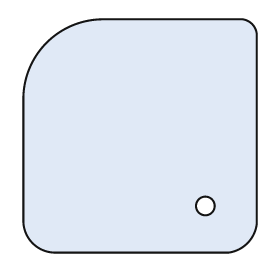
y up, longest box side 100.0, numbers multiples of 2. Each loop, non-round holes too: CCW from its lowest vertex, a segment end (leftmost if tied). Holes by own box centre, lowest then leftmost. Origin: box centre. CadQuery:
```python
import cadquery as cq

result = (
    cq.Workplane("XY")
    .moveTo(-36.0, -50.0)
    .lineTo(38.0, -50.0)
    .threePointArc((46.0, -46.0), (50.0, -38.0))
    .lineTo(50.0, 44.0)
    .threePointArc((48.0, 48.0), (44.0, 50.0))
    .lineTo(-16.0, 50.0)
    .threePointArc((-40.0, 40.0), (-50.0, 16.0))
    .lineTo(-50.0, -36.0)
    .threePointArc((-46.0, -46.0), (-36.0, -50.0))
    .close()
    .moveTo(28.0, -30.0)
    .circle(4.0)
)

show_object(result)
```